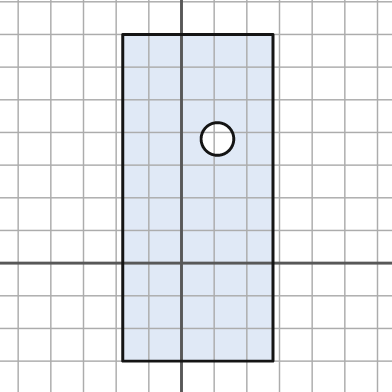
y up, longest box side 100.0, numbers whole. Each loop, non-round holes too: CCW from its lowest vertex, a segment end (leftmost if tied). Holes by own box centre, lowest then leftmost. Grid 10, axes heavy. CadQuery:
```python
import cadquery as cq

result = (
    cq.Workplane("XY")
    .moveTo(-18.0, -30.0)
    .lineTo(28.0, -30.0)
    .lineTo(28.0, 70.0)
    .lineTo(-18.0, 70.0)
    .close()
    .moveTo(11.0, 38.0)
    .circle(5.0)
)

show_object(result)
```